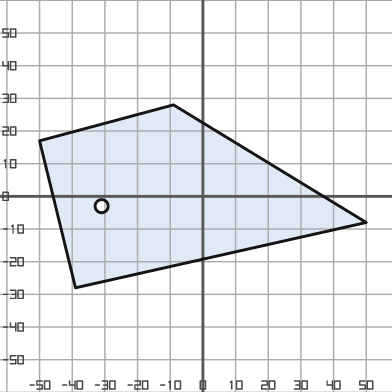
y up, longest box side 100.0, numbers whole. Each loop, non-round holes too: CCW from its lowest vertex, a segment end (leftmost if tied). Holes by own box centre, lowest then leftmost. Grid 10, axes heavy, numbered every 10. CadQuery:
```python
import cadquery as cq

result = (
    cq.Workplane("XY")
    .moveTo(-39.0, -28.0)
    .lineTo(50.0, -8.0)
    .lineTo(-9.0, 28.0)
    .lineTo(-50.0, 17.0)
    .close()
    .moveTo(-31.0, -3.0)
    .circle(2.0)
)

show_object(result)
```